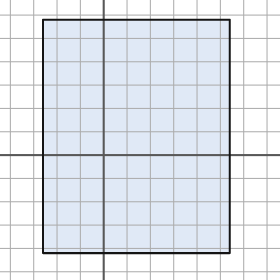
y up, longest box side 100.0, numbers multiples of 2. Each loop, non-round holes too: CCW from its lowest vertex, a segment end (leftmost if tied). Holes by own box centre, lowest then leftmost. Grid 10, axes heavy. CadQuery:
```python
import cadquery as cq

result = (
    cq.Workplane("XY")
    .moveTo(-26.0, -42.0)
    .lineTo(54.0, -42.0)
    .lineTo(54.0, 58.0)
    .lineTo(-26.0, 58.0)
    .close()
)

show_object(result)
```